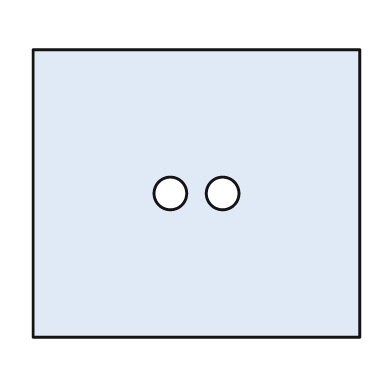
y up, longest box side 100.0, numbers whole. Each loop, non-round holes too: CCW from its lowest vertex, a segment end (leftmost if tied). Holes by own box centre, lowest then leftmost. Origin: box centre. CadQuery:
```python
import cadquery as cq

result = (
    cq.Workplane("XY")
    .moveTo(-50.0, -44.0)
    .lineTo(50.0, -44.0)
    .lineTo(50.0, 44.0)
    .lineTo(-50.0, 44.0)
    .close()
    .moveTo(-8.0, 0.0)
    .circle(5.0)
    .moveTo(8.0, 0.0)
    .circle(5.0)
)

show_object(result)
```